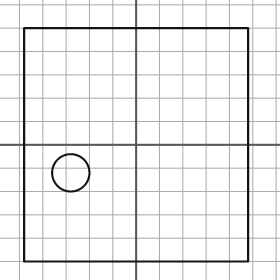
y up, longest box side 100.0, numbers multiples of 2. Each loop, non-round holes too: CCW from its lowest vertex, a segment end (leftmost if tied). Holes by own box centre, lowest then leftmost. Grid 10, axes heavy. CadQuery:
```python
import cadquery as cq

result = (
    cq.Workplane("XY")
    .moveTo(-48.0, -50.0)
    .lineTo(48.0, -50.0)
    .lineTo(48.0, 50.0)
    .lineTo(-48.0, 50.0)
    .close()
    .moveTo(-28.0, -12.0)
    .circle(8.0)
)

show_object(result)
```